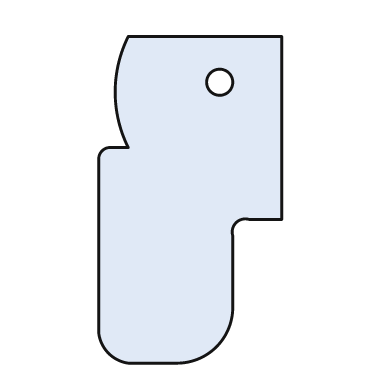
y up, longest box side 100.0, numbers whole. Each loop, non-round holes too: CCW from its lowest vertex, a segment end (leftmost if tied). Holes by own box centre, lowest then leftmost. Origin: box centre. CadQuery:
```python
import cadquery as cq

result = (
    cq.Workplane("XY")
    .moveTo(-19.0, -50.0)
    .lineTo(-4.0, -50.0)
    .threePointArc((8.0, -45.0), (13.0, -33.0))
    .lineTo(13.0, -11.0)
    .threePointArc((14.0, -7.0), (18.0, -6.0))
    .lineTo(28.0, -6.0)
    .lineTo(28.0, 50.0)
    .lineTo(-19.0, 50.0)
    .threePointArc((-23.0, 33.0), (-19.0, 16.0))
    .lineTo(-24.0, 16.0)
    .threePointArc((-27.0, 15.0), (-28.0, 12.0))
    .lineTo(-28.0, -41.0)
    .threePointArc((-25.0, -47.0), (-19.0, -50.0))
    .close()
    .moveTo(9.0, 36.0)
    .circle(4.0)
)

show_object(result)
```